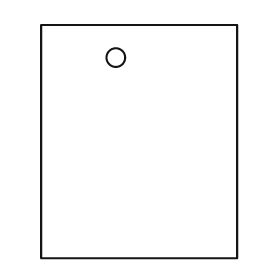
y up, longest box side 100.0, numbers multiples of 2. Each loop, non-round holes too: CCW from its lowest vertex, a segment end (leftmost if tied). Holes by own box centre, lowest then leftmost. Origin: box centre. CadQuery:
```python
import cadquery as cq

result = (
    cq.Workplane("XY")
    .moveTo(-42.0, -50.0)
    .lineTo(42.0, -50.0)
    .lineTo(42.0, 50.0)
    .lineTo(-42.0, 50.0)
    .close()
    .moveTo(-10.0, 36.0)
    .circle(4.0)
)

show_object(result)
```